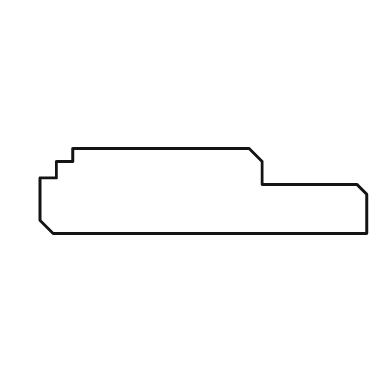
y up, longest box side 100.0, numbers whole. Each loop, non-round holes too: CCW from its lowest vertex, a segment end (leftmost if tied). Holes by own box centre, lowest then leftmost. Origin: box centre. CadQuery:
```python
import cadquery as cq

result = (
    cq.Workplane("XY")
    .moveTo(-46.0, -13.0)
    .lineTo(50.0, -13.0)
    .lineTo(50.0, -1.0)
    .lineTo(47.0, 2.0)
    .lineTo(18.0, 2.0)
    .lineTo(18.0, 9.0)
    .lineTo(14.0, 13.0)
    .lineTo(-40.0, 13.0)
    .lineTo(-40.0, 9.0)
    .lineTo(-45.0, 9.0)
    .lineTo(-45.0, 4.0)
    .lineTo(-50.0, 4.0)
    .lineTo(-50.0, -9.0)
    .close()
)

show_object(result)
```